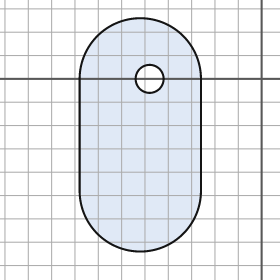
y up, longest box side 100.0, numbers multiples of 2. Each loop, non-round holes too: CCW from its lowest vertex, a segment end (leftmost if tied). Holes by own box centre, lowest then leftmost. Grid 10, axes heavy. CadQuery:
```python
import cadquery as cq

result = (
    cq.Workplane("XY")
    .moveTo(-78.0, -48.0)
    .threePointArc((-52.0, -74.0), (-26.0, -48.0))
    .lineTo(-26.0, 0.0)
    .threePointArc((-52.0, 26.0), (-78.0, 0.0))
    .close()
    .moveTo(-48.0, 0.0)
    .circle(6.0)
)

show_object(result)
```